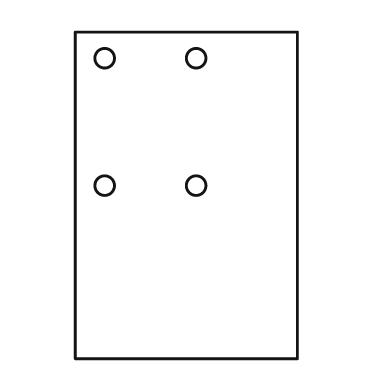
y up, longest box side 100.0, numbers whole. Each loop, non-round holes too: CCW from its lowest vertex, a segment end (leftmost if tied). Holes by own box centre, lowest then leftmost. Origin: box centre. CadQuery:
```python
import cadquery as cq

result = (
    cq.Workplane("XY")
    .moveTo(-34.0, -50.0)
    .lineTo(34.0, -50.0)
    .lineTo(34.0, 50.0)
    .lineTo(-34.0, 50.0)
    .close()
    .moveTo(-25.0, 3.0)
    .circle(3.0)
    .moveTo(3.0, 3.0)
    .circle(3.0)
    .moveTo(-25.0, 42.0)
    .circle(3.0)
    .moveTo(3.0, 42.0)
    .circle(3.0)
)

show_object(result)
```